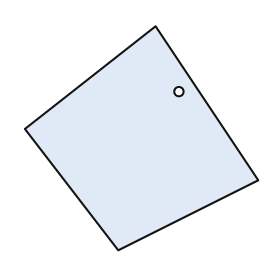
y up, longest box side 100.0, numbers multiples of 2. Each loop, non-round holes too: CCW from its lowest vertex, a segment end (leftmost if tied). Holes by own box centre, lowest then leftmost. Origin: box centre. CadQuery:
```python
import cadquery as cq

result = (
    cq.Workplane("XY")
    .moveTo(-10.0, -48.0)
    .lineTo(50.0, -18.0)
    .lineTo(6.0, 48.0)
    .lineTo(-50.0, 4.0)
    .close()
    .moveTo(16.0, 20.0)
    .circle(2.0)
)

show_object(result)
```